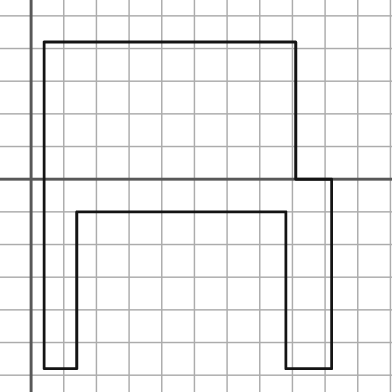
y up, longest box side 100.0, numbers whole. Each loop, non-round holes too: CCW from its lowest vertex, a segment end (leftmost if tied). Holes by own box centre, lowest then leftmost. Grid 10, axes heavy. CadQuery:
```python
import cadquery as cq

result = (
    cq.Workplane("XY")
    .moveTo(4.0, -58.0)
    .lineTo(14.0, -58.0)
    .lineTo(14.0, -10.0)
    .lineTo(78.0, -10.0)
    .lineTo(78.0, -58.0)
    .lineTo(92.0, -58.0)
    .lineTo(92.0, 0.0)
    .lineTo(81.0, 0.0)
    .lineTo(81.0, 42.0)
    .lineTo(4.0, 42.0)
    .close()
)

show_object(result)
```